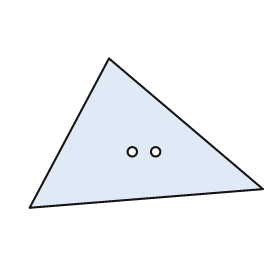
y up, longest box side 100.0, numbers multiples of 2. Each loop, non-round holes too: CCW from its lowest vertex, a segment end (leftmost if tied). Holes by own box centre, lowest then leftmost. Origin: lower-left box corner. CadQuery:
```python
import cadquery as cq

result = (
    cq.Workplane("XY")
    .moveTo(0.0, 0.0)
    .lineTo(100.0, 8.0)
    .lineTo(34.0, 64.0)
    .close()
    .moveTo(44.0, 24.0)
    .circle(2.0)
    .moveTo(54.0, 24.0)
    .circle(2.0)
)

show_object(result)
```